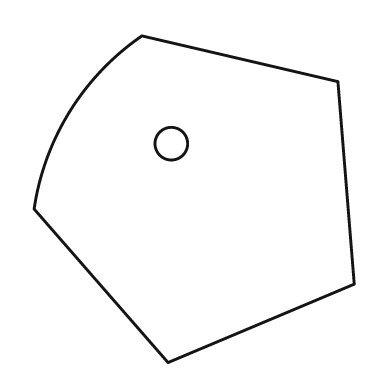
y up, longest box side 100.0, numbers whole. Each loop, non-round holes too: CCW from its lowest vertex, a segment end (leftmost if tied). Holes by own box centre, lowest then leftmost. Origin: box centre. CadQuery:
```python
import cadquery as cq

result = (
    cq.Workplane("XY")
    .moveTo(-8.0, -50.0)
    .lineTo(49.0, -26.0)
    .lineTo(44.0, 36.0)
    .lineTo(-16.0, 50.0)
    .threePointArc((-38.0, 27.0), (-49.0, -3.0))
    .close()
    .moveTo(-7.0, 17.0)
    .circle(5.0)
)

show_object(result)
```